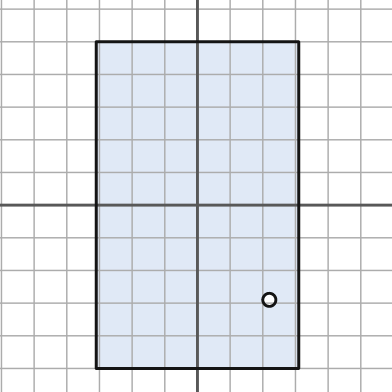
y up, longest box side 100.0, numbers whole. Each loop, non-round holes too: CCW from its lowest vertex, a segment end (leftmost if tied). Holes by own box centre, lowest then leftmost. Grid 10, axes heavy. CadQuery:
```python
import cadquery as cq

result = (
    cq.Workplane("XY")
    .moveTo(-31.0, -50.0)
    .lineTo(31.0, -50.0)
    .lineTo(31.0, 50.0)
    .lineTo(-31.0, 50.0)
    .close()
    .moveTo(22.0, -29.0)
    .circle(2.0)
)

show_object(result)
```